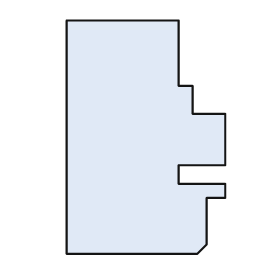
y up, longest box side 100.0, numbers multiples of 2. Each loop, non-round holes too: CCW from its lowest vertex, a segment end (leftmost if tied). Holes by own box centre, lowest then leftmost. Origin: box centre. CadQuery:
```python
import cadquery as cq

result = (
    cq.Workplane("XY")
    .moveTo(-34.0, -50.0)
    .lineTo(22.0, -50.0)
    .lineTo(26.0, -46.0)
    .lineTo(26.0, -26.0)
    .lineTo(34.0, -26.0)
    .lineTo(34.0, -20.0)
    .lineTo(14.0, -20.0)
    .lineTo(14.0, -12.0)
    .lineTo(34.0, -12.0)
    .lineTo(34.0, 10.0)
    .lineTo(20.0, 10.0)
    .lineTo(20.0, 22.0)
    .lineTo(14.0, 22.0)
    .lineTo(14.0, 50.0)
    .lineTo(-34.0, 50.0)
    .close()
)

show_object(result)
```